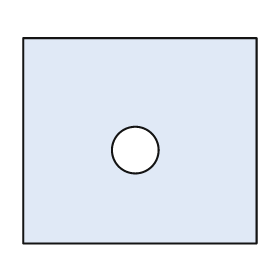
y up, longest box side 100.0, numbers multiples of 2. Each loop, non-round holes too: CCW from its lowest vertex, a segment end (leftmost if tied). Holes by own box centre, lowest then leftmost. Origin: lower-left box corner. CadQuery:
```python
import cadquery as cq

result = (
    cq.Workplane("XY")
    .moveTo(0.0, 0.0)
    .lineTo(100.0, 0.0)
    .lineTo(100.0, 88.0)
    .lineTo(0.0, 88.0)
    .close()
    .moveTo(48.0, 40.0)
    .circle(10.0)
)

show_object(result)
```